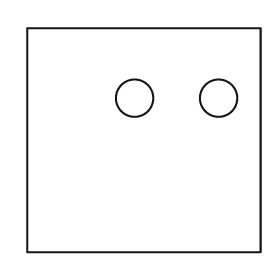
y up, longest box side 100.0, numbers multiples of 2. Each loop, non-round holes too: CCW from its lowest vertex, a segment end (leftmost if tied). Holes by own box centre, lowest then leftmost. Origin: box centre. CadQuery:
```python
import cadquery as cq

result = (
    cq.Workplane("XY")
    .moveTo(-50.0, -48.0)
    .lineTo(50.0, -48.0)
    .lineTo(50.0, 48.0)
    .lineTo(-50.0, 48.0)
    .close()
    .moveTo(-4.0, 18.0)
    .circle(8.0)
    .moveTo(32.0, 18.0)
    .circle(8.0)
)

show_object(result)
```